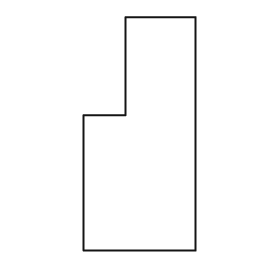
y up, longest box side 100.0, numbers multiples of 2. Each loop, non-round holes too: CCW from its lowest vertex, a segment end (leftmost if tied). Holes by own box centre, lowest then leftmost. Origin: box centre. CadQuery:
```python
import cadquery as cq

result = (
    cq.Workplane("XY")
    .moveTo(-24.0, -50.0)
    .lineTo(24.0, -50.0)
    .lineTo(24.0, 50.0)
    .lineTo(-6.0, 50.0)
    .lineTo(-6.0, 8.0)
    .lineTo(-24.0, 8.0)
    .close()
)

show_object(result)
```